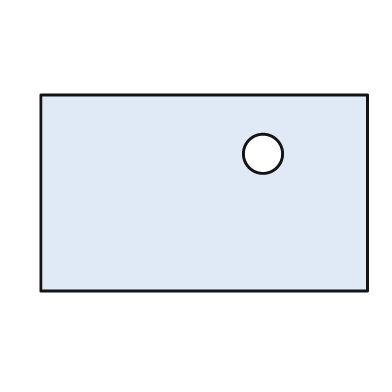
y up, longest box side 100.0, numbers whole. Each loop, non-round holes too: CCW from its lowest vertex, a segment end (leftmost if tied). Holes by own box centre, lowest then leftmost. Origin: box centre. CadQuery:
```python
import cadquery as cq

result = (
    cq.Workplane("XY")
    .moveTo(-50.0, -30.0)
    .lineTo(50.0, -30.0)
    .lineTo(50.0, 30.0)
    .lineTo(-50.0, 30.0)
    .close()
    .moveTo(18.0, 12.0)
    .circle(6.0)
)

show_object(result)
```